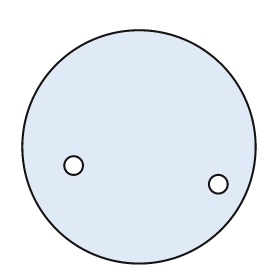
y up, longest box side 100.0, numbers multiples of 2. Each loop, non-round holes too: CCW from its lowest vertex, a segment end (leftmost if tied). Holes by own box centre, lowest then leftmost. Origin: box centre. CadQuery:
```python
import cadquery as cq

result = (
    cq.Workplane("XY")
    .moveTo(0.0, 0.0)
    .circle(50.0)
    .moveTo(34.0, -16.0)
    .circle(4.0)
    .moveTo(-28.0, -8.0)
    .circle(4.0)
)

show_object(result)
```